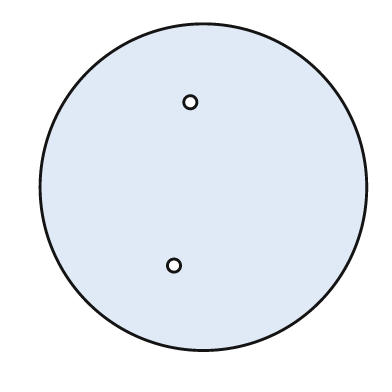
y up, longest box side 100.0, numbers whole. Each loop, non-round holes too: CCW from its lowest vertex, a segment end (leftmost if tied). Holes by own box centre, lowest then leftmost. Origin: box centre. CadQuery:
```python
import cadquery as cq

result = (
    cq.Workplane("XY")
    .moveTo(0.0, 0.0)
    .circle(50.0)
    .moveTo(-9.0, -24.0)
    .circle(2.0)
    .moveTo(-4.0, 26.0)
    .circle(2.0)
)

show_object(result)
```